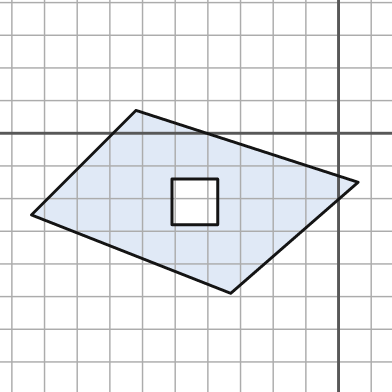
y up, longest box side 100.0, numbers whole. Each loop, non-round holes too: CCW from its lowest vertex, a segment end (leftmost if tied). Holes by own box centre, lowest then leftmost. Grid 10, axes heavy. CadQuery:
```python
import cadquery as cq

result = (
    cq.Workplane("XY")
    .moveTo(-33.0, -49.0)
    .lineTo(6.0, -15.0)
    .lineTo(-62.0, 7.0)
    .lineTo(-94.0, -25.0)
    .close()
    .moveTo(-51.0, -28.0)
    .lineTo(-37.0, -28.0)
    .lineTo(-37.0, -14.0)
    .lineTo(-51.0, -14.0)
    .close()
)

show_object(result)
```